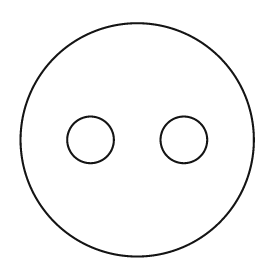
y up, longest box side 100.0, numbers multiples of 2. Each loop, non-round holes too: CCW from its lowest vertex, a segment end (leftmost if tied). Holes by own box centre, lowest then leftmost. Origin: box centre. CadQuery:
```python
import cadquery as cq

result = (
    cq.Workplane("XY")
    .moveTo(0.0, 0.0)
    .circle(50.0)
    .moveTo(-20.0, 0.0)
    .circle(10.0)
    .moveTo(20.0, 0.0)
    .circle(10.0)
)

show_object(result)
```